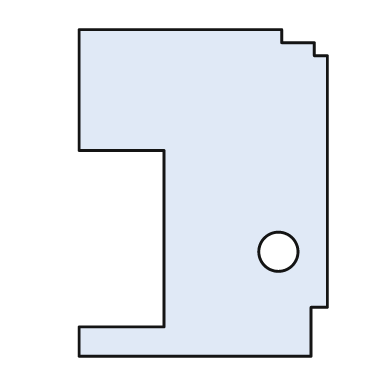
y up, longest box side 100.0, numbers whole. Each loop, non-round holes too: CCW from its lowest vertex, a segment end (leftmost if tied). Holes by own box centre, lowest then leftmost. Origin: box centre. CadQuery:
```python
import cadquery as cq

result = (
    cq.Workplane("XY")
    .moveTo(-38.0, -50.0)
    .lineTo(33.0, -50.0)
    .lineTo(33.0, -35.0)
    .lineTo(38.0, -35.0)
    .lineTo(38.0, 42.0)
    .lineTo(34.0, 42.0)
    .lineTo(34.0, 46.0)
    .lineTo(24.0, 46.0)
    .lineTo(24.0, 50.0)
    .lineTo(-38.0, 50.0)
    .lineTo(-38.0, 13.0)
    .lineTo(-12.0, 13.0)
    .lineTo(-12.0, -41.0)
    .lineTo(-38.0, -41.0)
    .close()
    .moveTo(23.0, -18.0)
    .circle(6.0)
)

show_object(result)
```